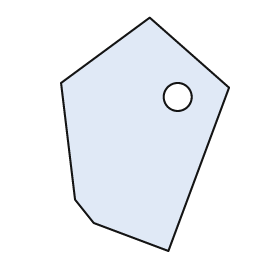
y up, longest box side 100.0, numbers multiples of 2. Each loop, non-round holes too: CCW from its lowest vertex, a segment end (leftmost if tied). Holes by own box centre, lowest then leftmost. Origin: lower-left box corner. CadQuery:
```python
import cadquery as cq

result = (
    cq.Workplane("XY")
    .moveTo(46.0, 0.0)
    .lineTo(72.0, 70.0)
    .lineTo(38.0, 100.0)
    .lineTo(0.0, 72.0)
    .lineTo(6.0, 22.0)
    .lineTo(14.0, 12.0)
    .close()
    .moveTo(50.0, 66.0)
    .circle(6.0)
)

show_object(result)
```